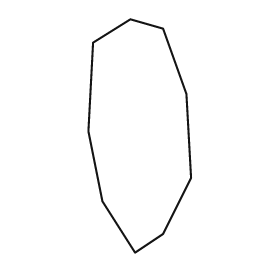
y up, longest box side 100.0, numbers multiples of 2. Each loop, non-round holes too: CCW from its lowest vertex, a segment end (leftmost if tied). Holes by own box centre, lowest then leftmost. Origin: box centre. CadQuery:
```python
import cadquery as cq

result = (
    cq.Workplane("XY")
    .moveTo(-2.0, -50.0)
    .lineTo(10.0, -42.0)
    .lineTo(22.0, -18.0)
    .lineTo(20.0, 18.0)
    .lineTo(10.0, 46.0)
    .lineTo(-4.0, 50.0)
    .lineTo(-20.0, 40.0)
    .lineTo(-22.0, 2.0)
    .lineTo(-16.0, -28.0)
    .close()
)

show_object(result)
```